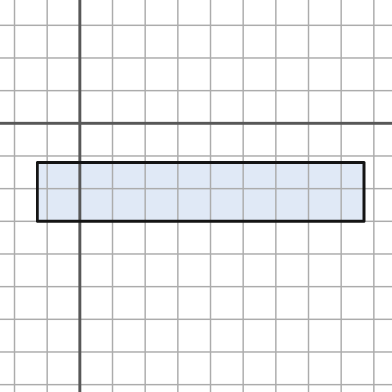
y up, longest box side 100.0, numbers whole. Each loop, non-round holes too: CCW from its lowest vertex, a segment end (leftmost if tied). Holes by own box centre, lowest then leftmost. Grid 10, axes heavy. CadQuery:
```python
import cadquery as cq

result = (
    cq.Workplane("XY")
    .moveTo(-13.0, -30.0)
    .lineTo(87.0, -30.0)
    .lineTo(87.0, -12.0)
    .lineTo(-13.0, -12.0)
    .close()
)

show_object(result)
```